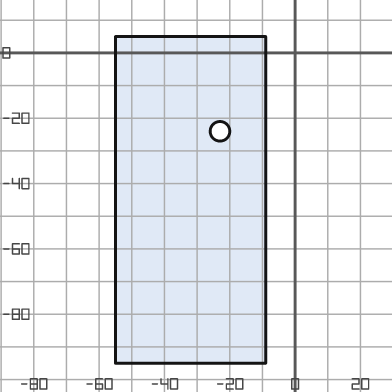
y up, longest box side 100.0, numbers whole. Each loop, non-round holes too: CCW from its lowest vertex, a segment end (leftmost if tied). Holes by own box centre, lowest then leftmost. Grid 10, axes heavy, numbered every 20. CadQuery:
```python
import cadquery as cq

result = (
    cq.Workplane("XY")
    .moveTo(-55.0, -95.0)
    .lineTo(-9.0, -95.0)
    .lineTo(-9.0, 5.0)
    .lineTo(-55.0, 5.0)
    .close()
    .moveTo(-23.0, -24.0)
    .circle(3.0)
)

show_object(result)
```